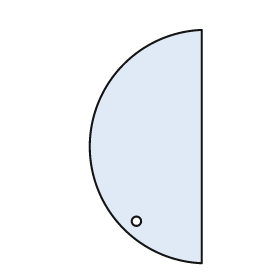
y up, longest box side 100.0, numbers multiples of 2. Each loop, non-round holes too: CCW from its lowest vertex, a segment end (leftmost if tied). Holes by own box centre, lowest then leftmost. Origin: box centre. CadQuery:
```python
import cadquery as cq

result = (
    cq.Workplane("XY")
    .moveTo(24.0, -50.0)
    .lineTo(24.0, 50.0)
    .threePointArc((-24.0, 0.0), (24.0, -50.0))
    .close()
    .moveTo(-4.0, -32.0)
    .circle(2.0)
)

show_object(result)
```